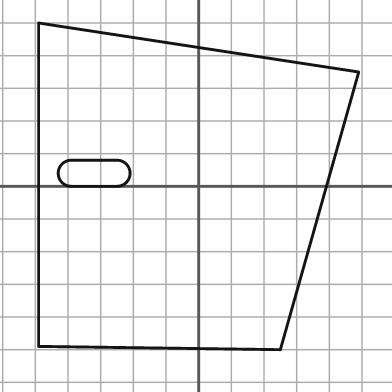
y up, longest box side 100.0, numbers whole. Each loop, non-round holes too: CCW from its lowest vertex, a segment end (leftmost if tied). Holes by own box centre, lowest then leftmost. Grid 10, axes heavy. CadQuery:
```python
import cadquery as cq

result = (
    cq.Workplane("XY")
    .moveTo(25.0, -50.0)
    .lineTo(49.0, 35.0)
    .lineTo(-49.0, 50.0)
    .lineTo(-49.0, -49.0)
    .close()
    .moveTo(-39.0, 0.0)
    .lineTo(-25.0, 0.0)
    .threePointArc((-21.0, 4.0), (-25.0, 8.0))
    .lineTo(-39.0, 8.0)
    .threePointArc((-43.0, 4.0), (-39.0, 0.0))
    .close()
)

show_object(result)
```